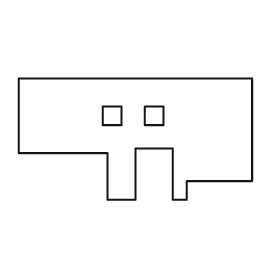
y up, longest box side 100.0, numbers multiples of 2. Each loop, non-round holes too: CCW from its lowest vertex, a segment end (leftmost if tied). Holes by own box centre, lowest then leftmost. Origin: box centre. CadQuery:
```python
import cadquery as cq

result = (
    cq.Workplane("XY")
    .moveTo(-12.0, -26.0)
    .lineTo(0.0, -26.0)
    .lineTo(0.0, -4.0)
    .lineTo(16.0, -4.0)
    .lineTo(16.0, -26.0)
    .lineTo(22.0, -26.0)
    .lineTo(22.0, -18.0)
    .lineTo(50.0, -18.0)
    .lineTo(50.0, 26.0)
    .lineTo(-50.0, 26.0)
    .lineTo(-50.0, -6.0)
    .lineTo(-12.0, -6.0)
    .close()
    .moveTo(-14.0, 6.0)
    .lineTo(-6.0, 6.0)
    .lineTo(-6.0, 14.0)
    .lineTo(-14.0, 14.0)
    .close()
    .moveTo(4.0, 6.0)
    .lineTo(12.0, 6.0)
    .lineTo(12.0, 14.0)
    .lineTo(4.0, 14.0)
    .close()
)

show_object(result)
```